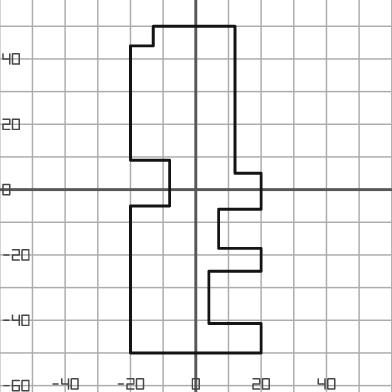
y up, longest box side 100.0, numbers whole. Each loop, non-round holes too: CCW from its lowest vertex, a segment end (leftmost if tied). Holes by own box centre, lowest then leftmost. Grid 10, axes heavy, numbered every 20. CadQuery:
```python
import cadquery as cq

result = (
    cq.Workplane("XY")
    .moveTo(-20.0, -50.0)
    .lineTo(20.0, -50.0)
    .lineTo(20.0, -41.0)
    .lineTo(4.0, -41.0)
    .lineTo(4.0, -25.0)
    .lineTo(20.0, -25.0)
    .lineTo(20.0, -18.0)
    .lineTo(7.0, -18.0)
    .lineTo(7.0, -6.0)
    .lineTo(20.0, -6.0)
    .lineTo(20.0, 5.0)
    .lineTo(12.0, 5.0)
    .lineTo(12.0, 50.0)
    .lineTo(-13.0, 50.0)
    .lineTo(-13.0, 44.0)
    .lineTo(-20.0, 44.0)
    .lineTo(-20.0, 9.0)
    .lineTo(-8.0, 9.0)
    .lineTo(-8.0, -5.0)
    .lineTo(-20.0, -5.0)
    .close()
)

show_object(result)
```